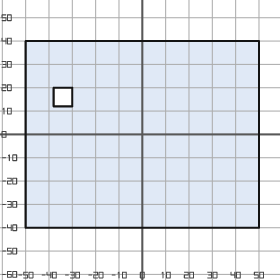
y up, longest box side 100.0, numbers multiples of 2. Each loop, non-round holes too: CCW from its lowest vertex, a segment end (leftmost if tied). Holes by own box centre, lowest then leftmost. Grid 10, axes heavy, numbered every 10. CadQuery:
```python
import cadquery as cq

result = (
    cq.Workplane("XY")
    .moveTo(-50.0, -40.0)
    .lineTo(50.0, -40.0)
    .lineTo(50.0, 40.0)
    .lineTo(-50.0, 40.0)
    .close()
    .moveTo(-38.0, 12.0)
    .lineTo(-30.0, 12.0)
    .lineTo(-30.0, 20.0)
    .lineTo(-38.0, 20.0)
    .close()
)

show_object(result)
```